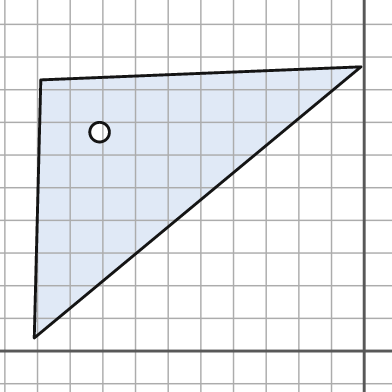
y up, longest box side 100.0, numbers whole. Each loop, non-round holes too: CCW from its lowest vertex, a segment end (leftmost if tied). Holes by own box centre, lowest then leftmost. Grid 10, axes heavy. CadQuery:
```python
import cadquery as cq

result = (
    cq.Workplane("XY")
    .moveTo(-101.0, 4.0)
    .lineTo(-1.0, 87.0)
    .lineTo(-99.0, 83.0)
    .close()
    .moveTo(-81.0, 67.0)
    .circle(3.0)
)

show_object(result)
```